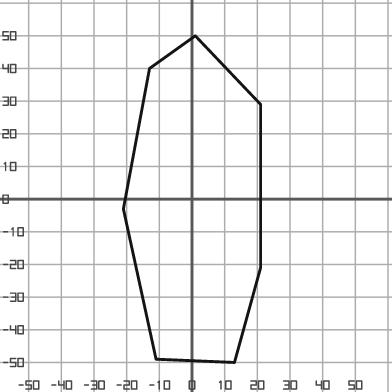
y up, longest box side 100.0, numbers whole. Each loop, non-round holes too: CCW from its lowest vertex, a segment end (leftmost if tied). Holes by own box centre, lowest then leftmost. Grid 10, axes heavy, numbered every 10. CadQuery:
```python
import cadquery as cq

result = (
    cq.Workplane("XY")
    .moveTo(13.0, -50.0)
    .lineTo(21.0, -21.0)
    .lineTo(21.0, 29.0)
    .lineTo(1.0, 50.0)
    .lineTo(-13.0, 40.0)
    .lineTo(-21.0, -3.0)
    .lineTo(-11.0, -49.0)
    .close()
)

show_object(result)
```